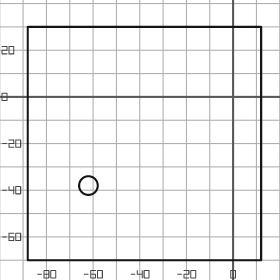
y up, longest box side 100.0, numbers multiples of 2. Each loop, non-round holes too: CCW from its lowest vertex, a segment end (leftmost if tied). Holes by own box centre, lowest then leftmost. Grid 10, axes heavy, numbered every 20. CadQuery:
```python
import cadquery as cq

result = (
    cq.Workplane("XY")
    .moveTo(-88.0, -70.0)
    .lineTo(12.0, -70.0)
    .lineTo(12.0, 30.0)
    .lineTo(-88.0, 30.0)
    .close()
    .moveTo(-62.0, -38.0)
    .circle(4.0)
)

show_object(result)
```